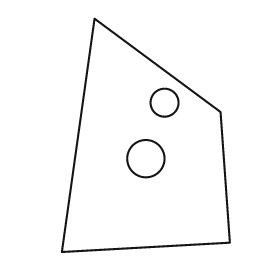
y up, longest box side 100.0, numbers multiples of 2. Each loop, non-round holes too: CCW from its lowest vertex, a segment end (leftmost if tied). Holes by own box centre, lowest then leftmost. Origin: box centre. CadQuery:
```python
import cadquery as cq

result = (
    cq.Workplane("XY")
    .moveTo(-36.0, -50.0)
    .lineTo(36.0, -46.0)
    .lineTo(32.0, 10.0)
    .lineTo(-22.0, 50.0)
    .close()
    .moveTo(0.0, -10.0)
    .circle(8.0)
    .moveTo(8.0, 14.0)
    .circle(6.0)
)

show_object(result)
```